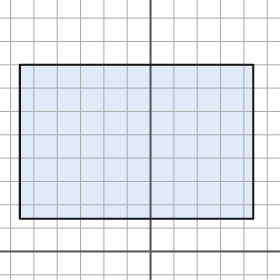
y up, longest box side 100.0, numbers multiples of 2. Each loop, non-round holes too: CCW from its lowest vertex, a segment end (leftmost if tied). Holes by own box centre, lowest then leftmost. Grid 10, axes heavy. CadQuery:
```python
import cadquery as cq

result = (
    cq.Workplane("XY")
    .moveTo(-56.0, 14.0)
    .lineTo(44.0, 14.0)
    .lineTo(44.0, 80.0)
    .lineTo(-56.0, 80.0)
    .close()
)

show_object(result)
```